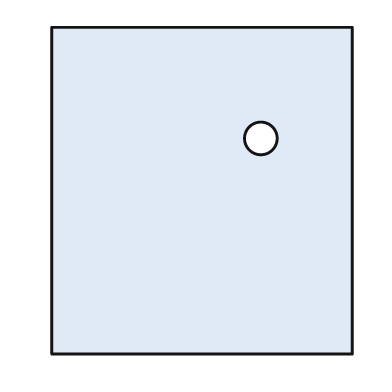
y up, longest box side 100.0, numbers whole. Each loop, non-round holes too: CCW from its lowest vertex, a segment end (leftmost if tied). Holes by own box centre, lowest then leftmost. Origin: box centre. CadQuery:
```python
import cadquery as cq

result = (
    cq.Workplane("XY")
    .moveTo(-46.0, -50.0)
    .lineTo(46.0, -50.0)
    .lineTo(46.0, 50.0)
    .lineTo(-46.0, 50.0)
    .close()
    .moveTo(18.0, 16.0)
    .circle(5.0)
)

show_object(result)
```